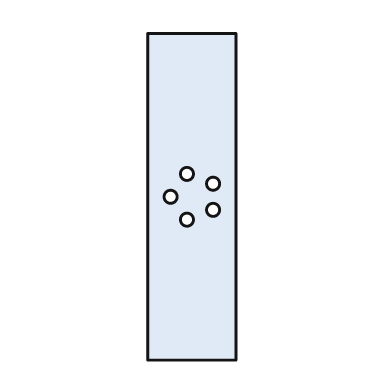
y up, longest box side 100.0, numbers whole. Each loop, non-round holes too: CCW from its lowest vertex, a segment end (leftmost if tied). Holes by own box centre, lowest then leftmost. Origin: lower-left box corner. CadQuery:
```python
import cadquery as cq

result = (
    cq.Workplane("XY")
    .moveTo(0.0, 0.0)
    .lineTo(27.0, 0.0)
    .lineTo(27.0, 100.0)
    .lineTo(0.0, 100.0)
    .close()
    .moveTo(12.0, 43.0)
    .circle(2.0)
    .moveTo(20.0, 46.0)
    .circle(2.0)
    .moveTo(7.0, 50.0)
    .circle(2.0)
    .moveTo(20.0, 54.0)
    .circle(2.0)
    .moveTo(12.0, 57.0)
    .circle(2.0)
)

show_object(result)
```